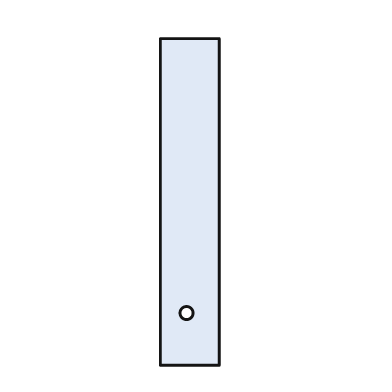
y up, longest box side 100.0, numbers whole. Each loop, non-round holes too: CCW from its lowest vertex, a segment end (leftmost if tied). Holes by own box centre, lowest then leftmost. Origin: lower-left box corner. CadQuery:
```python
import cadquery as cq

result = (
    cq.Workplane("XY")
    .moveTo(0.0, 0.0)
    .lineTo(18.0, 0.0)
    .lineTo(18.0, 100.0)
    .lineTo(0.0, 100.0)
    .close()
    .moveTo(8.0, 16.0)
    .circle(2.0)
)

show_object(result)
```